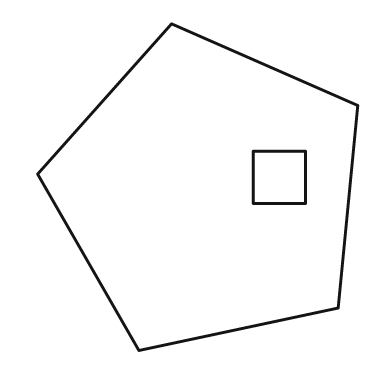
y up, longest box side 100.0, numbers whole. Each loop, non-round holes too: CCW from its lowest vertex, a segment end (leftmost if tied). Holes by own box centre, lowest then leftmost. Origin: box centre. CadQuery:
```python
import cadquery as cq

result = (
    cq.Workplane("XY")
    .moveTo(-18.0, -50.0)
    .lineTo(43.0, -37.0)
    .lineTo(49.0, 25.0)
    .lineTo(-8.0, 50.0)
    .lineTo(-49.0, 4.0)
    .close()
    .moveTo(17.0, -5.0)
    .lineTo(33.0, -5.0)
    .lineTo(33.0, 11.0)
    .lineTo(17.0, 11.0)
    .close()
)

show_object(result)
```